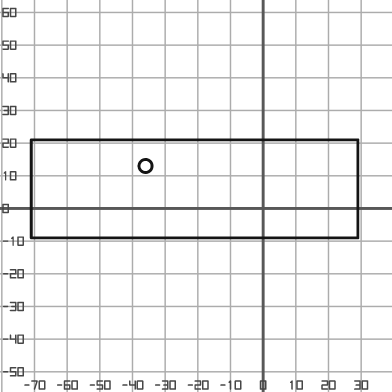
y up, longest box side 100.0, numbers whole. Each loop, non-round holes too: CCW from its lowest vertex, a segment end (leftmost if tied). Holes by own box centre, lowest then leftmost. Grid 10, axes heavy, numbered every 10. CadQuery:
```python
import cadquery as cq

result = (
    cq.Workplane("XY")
    .moveTo(-71.0, -9.0)
    .lineTo(29.0, -9.0)
    .lineTo(29.0, 21.0)
    .lineTo(-71.0, 21.0)
    .close()
    .moveTo(-36.0, 13.0)
    .circle(2.0)
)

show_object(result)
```